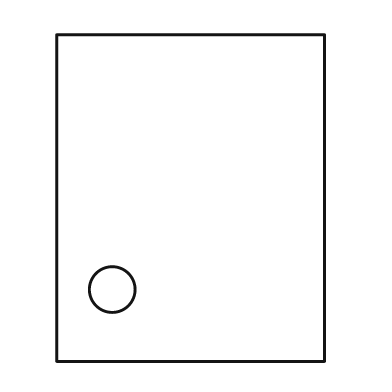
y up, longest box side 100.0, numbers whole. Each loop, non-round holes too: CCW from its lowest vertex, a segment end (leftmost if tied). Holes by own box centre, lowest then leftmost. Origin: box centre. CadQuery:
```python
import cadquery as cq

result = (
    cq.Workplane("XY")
    .moveTo(-41.0, -50.0)
    .lineTo(41.0, -50.0)
    .lineTo(41.0, 50.0)
    .lineTo(-41.0, 50.0)
    .close()
    .moveTo(-24.0, -28.0)
    .circle(7.0)
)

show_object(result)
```